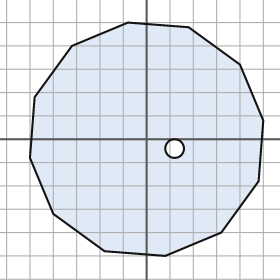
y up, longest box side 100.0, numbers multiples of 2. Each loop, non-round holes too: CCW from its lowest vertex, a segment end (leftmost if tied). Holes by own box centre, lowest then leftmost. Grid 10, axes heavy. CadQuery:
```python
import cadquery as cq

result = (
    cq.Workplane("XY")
    .moveTo(8.0, -50.0)
    .lineTo(32.0, -40.0)
    .lineTo(48.0, -18.0)
    .lineTo(50.0, 8.0)
    .lineTo(40.0, 32.0)
    .lineTo(18.0, 48.0)
    .lineTo(-8.0, 50.0)
    .lineTo(-32.0, 40.0)
    .lineTo(-48.0, 18.0)
    .lineTo(-50.0, -8.0)
    .lineTo(-40.0, -32.0)
    .lineTo(-18.0, -48.0)
    .close()
    .moveTo(12.0, -4.0)
    .circle(4.0)
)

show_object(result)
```